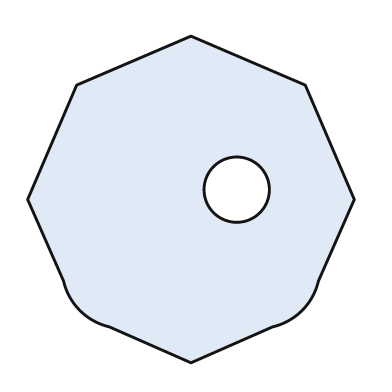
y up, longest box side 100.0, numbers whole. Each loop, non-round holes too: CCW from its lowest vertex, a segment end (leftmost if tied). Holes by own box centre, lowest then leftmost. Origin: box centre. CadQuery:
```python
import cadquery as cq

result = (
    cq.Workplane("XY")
    .moveTo(0.0, -50.0)
    .lineTo(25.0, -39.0)
    .threePointArc((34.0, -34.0), (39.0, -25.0))
    .lineTo(50.0, 0.0)
    .lineTo(35.0, 35.0)
    .lineTo(0.0, 50.0)
    .lineTo(-35.0, 35.0)
    .lineTo(-50.0, 0.0)
    .lineTo(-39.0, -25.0)
    .threePointArc((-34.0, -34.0), (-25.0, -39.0))
    .close()
    .moveTo(14.0, 3.0)
    .circle(10.0)
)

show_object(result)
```